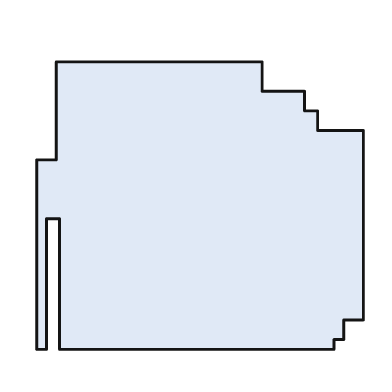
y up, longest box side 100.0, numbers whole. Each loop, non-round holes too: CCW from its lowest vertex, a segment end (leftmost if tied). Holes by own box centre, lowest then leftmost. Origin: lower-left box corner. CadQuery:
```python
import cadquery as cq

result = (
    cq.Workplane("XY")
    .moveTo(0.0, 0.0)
    .lineTo(3.0, 0.0)
    .lineTo(3.0, 40.0)
    .lineTo(7.0, 40.0)
    .lineTo(7.0, 0.0)
    .lineTo(91.0, 0.0)
    .lineTo(91.0, 3.0)
    .lineTo(94.0, 3.0)
    .lineTo(94.0, 9.0)
    .lineTo(100.0, 9.0)
    .lineTo(100.0, 67.0)
    .lineTo(86.0, 67.0)
    .lineTo(86.0, 73.0)
    .lineTo(82.0, 73.0)
    .lineTo(82.0, 79.0)
    .lineTo(69.0, 79.0)
    .lineTo(69.0, 88.0)
    .lineTo(6.0, 88.0)
    .lineTo(6.0, 58.0)
    .lineTo(0.0, 58.0)
    .close()
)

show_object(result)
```